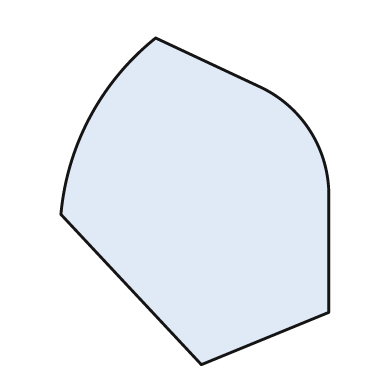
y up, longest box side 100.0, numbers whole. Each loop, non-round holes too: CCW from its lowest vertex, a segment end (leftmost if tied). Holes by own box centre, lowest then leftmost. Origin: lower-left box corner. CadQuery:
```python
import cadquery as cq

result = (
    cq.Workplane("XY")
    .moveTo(43.0, 0.0)
    .lineTo(82.0, 16.0)
    .lineTo(82.0, 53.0)
    .threePointArc((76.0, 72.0), (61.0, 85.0))
    .lineTo(29.0, 100.0)
    .threePointArc((9.0, 76.0), (0.0, 46.0))
    .close()
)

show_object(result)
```